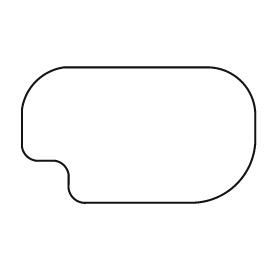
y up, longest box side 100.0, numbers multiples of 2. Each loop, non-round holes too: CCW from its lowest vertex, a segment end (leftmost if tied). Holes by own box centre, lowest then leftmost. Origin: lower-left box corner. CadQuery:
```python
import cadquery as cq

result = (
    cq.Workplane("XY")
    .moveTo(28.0, 0.0)
    .lineTo(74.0, 0.0)
    .threePointArc((92.0, 8.0), (100.0, 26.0))
    .lineTo(100.0, 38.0)
    .threePointArc((94.0, 52.0), (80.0, 58.0))
    .lineTo(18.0, 58.0)
    .threePointArc((6.0, 52.0), (0.0, 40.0))
    .lineTo(0.0, 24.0)
    .threePointArc((2.0, 20.0), (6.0, 18.0))
    .lineTo(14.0, 18.0)
    .threePointArc((18.0, 16.0), (20.0, 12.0))
    .lineTo(20.0, 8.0)
    .threePointArc((22.0, 2.0), (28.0, 0.0))
    .close()
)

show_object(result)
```